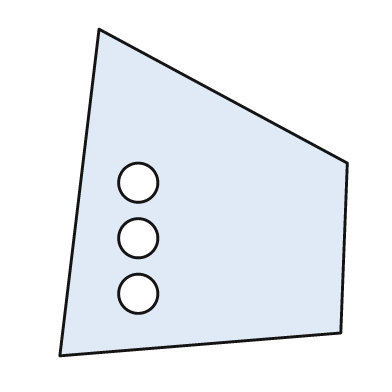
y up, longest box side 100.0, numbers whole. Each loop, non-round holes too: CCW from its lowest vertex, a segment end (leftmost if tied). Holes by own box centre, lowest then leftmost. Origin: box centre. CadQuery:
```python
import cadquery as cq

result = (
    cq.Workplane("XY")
    .moveTo(-44.0, -50.0)
    .lineTo(42.0, -43.0)
    .lineTo(44.0, 9.0)
    .lineTo(-32.0, 50.0)
    .close()
    .moveTo(-20.0, -31.0)
    .circle(6.0)
    .moveTo(-20.0, -14.0)
    .circle(6.0)
    .moveTo(-20.0, 3.0)
    .circle(6.0)
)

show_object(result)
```